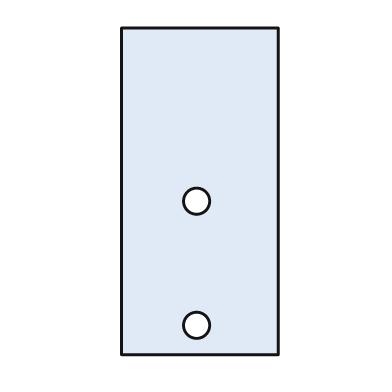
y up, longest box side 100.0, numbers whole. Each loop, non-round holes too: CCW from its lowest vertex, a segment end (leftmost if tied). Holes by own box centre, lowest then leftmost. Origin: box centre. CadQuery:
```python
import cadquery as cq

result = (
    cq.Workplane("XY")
    .moveTo(-24.0, -50.0)
    .lineTo(24.0, -50.0)
    .lineTo(24.0, 50.0)
    .lineTo(-24.0, 50.0)
    .close()
    .moveTo(-1.0, -41.0)
    .circle(4.0)
    .moveTo(-1.0, -3.0)
    .circle(4.0)
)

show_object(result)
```